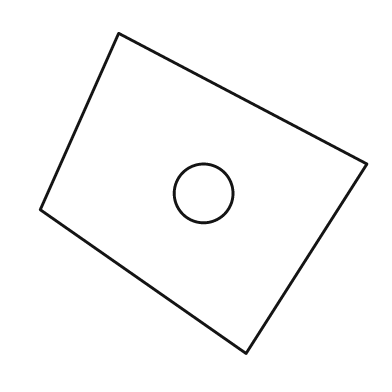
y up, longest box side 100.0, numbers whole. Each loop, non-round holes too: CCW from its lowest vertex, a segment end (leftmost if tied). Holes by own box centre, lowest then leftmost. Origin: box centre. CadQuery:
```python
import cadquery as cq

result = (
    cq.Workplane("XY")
    .moveTo(13.0, -49.0)
    .lineTo(50.0, 9.0)
    .lineTo(-26.0, 49.0)
    .lineTo(-50.0, -5.0)
    .close()
    .moveTo(0.0, 0.0)
    .circle(9.0)
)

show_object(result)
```